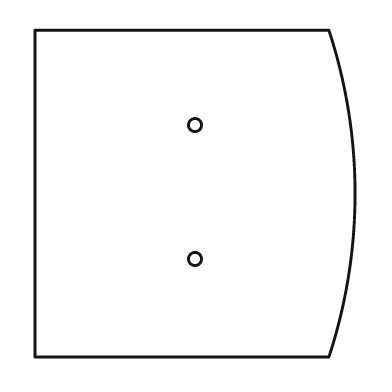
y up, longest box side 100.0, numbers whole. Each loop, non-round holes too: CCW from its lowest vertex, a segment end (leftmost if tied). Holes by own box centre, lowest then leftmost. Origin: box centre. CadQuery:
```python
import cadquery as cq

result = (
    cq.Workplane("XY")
    .moveTo(-49.0, -50.0)
    .lineTo(41.0, -50.0)
    .threePointArc((49.0, 0.0), (41.0, 50.0))
    .lineTo(-49.0, 50.0)
    .close()
    .moveTo(0.0, -20.0)
    .circle(2.0)
    .moveTo(0.0, 21.0)
    .circle(2.0)
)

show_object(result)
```